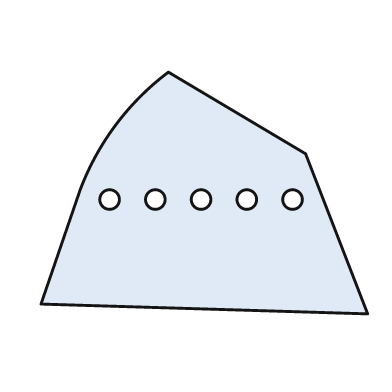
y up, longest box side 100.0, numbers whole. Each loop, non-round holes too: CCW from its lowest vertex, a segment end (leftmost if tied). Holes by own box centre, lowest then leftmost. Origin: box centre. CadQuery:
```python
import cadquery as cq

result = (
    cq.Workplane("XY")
    .moveTo(50.0, -37.0)
    .lineTo(31.0, 12.0)
    .lineTo(-11.0, 37.0)
    .threePointArc((-27.0, 21.0), (-38.0, 1.0))
    .lineTo(-50.0, -34.0)
    .close()
    .moveTo(-29.0, -2.0)
    .circle(3.0)
    .moveTo(-15.0, -2.0)
    .circle(3.0)
    .moveTo(-1.0, -2.0)
    .circle(3.0)
    .moveTo(13.0, -2.0)
    .circle(3.0)
    .moveTo(27.0, -2.0)
    .circle(3.0)
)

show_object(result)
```